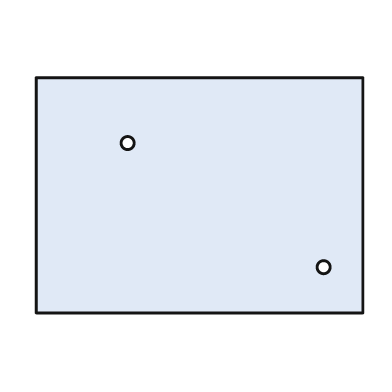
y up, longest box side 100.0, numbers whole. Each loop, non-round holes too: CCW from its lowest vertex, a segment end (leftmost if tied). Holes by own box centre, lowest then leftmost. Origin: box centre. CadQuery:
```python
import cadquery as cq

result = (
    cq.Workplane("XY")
    .moveTo(-50.0, -36.0)
    .lineTo(50.0, -36.0)
    .lineTo(50.0, 36.0)
    .lineTo(-50.0, 36.0)
    .close()
    .moveTo(38.0, -22.0)
    .circle(2.0)
    .moveTo(-22.0, 16.0)
    .circle(2.0)
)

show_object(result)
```